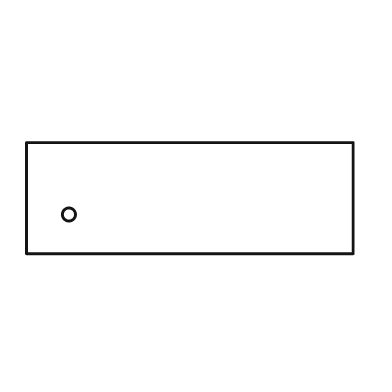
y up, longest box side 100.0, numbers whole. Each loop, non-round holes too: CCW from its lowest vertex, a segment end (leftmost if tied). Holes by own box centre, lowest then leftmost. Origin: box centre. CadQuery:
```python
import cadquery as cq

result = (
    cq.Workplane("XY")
    .moveTo(-50.0, -17.0)
    .lineTo(50.0, -17.0)
    .lineTo(50.0, 17.0)
    .lineTo(-50.0, 17.0)
    .close()
    .moveTo(-37.0, -5.0)
    .circle(2.0)
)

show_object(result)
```